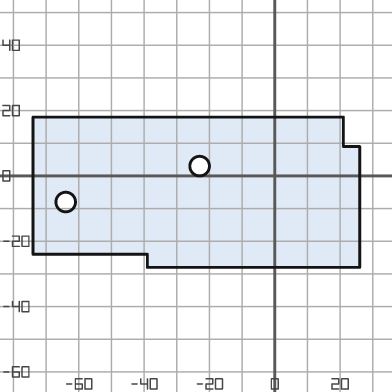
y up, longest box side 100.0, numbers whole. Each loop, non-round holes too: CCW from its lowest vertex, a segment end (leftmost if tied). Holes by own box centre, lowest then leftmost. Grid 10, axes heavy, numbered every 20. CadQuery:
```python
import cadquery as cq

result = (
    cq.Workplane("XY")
    .moveTo(-39.0, -28.0)
    .lineTo(26.0, -28.0)
    .lineTo(26.0, 9.0)
    .lineTo(21.0, 9.0)
    .lineTo(21.0, 18.0)
    .lineTo(-74.0, 18.0)
    .lineTo(-74.0, -24.0)
    .lineTo(-39.0, -24.0)
    .close()
    .moveTo(-64.0, -8.0)
    .circle(3.0)
    .moveTo(-23.0, 3.0)
    .circle(3.0)
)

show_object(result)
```